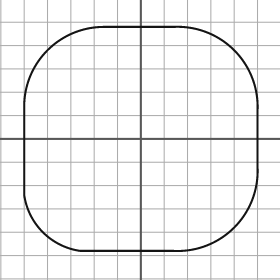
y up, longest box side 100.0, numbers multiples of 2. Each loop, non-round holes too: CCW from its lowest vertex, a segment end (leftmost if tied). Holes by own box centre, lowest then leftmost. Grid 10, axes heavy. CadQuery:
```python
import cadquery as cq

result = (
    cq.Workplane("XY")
    .moveTo(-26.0, -48.0)
    .lineTo(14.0, -48.0)
    .threePointArc((40.0, -38.0), (50.0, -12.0))
    .lineTo(50.0, 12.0)
    .threePointArc((40.0, 38.0), (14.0, 48.0))
    .lineTo(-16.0, 48.0)
    .threePointArc((-40.0, 38.0), (-50.0, 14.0))
    .lineTo(-50.0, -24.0)
    .threePointArc((-42.0, -40.0), (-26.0, -48.0))
    .close()
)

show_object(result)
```